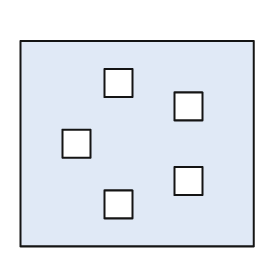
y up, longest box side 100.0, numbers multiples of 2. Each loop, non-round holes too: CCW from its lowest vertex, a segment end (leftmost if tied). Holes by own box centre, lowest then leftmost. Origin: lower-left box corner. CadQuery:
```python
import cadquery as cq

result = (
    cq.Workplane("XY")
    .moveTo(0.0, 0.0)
    .lineTo(100.0, 0.0)
    .lineTo(100.0, 88.0)
    .lineTo(0.0, 88.0)
    .close()
    .moveTo(36.0, 12.0)
    .lineTo(48.0, 12.0)
    .lineTo(48.0, 24.0)
    .lineTo(36.0, 24.0)
    .close()
    .moveTo(66.0, 22.0)
    .lineTo(78.0, 22.0)
    .lineTo(78.0, 34.0)
    .lineTo(66.0, 34.0)
    .close()
    .moveTo(18.0, 38.0)
    .lineTo(30.0, 38.0)
    .lineTo(30.0, 50.0)
    .lineTo(18.0, 50.0)
    .close()
    .moveTo(66.0, 54.0)
    .lineTo(78.0, 54.0)
    .lineTo(78.0, 66.0)
    .lineTo(66.0, 66.0)
    .close()
    .moveTo(36.0, 64.0)
    .lineTo(48.0, 64.0)
    .lineTo(48.0, 76.0)
    .lineTo(36.0, 76.0)
    .close()
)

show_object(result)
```